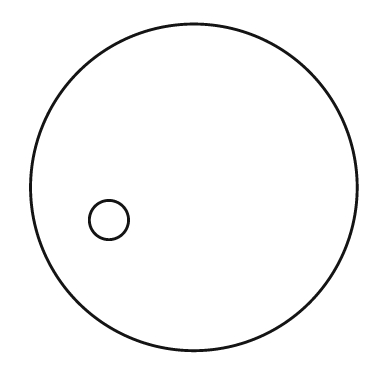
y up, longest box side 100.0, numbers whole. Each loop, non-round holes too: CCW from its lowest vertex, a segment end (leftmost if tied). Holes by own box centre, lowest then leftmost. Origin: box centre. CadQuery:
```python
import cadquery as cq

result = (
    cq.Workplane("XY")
    .moveTo(0.0, 0.0)
    .circle(50.0)
    .moveTo(-26.0, -10.0)
    .circle(6.0)
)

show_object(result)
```